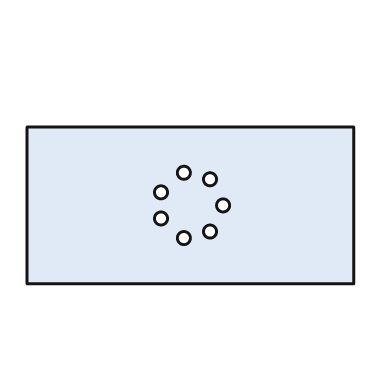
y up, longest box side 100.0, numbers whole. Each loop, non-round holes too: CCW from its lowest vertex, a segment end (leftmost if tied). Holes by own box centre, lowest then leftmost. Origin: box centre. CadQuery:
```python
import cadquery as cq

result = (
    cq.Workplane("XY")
    .moveTo(-50.0, -24.0)
    .lineTo(50.0, -24.0)
    .lineTo(50.0, 24.0)
    .lineTo(-50.0, 24.0)
    .close()
    .moveTo(-2.0, -10.0)
    .circle(2.0)
    .moveTo(6.0, -8.0)
    .circle(2.0)
    .moveTo(-9.0, -4.0)
    .circle(2.0)
    .moveTo(10.0, 0.0)
    .circle(2.0)
    .moveTo(-9.0, 4.0)
    .circle(2.0)
    .moveTo(6.0, 8.0)
    .circle(2.0)
    .moveTo(-2.0, 10.0)
    .circle(2.0)
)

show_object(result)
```